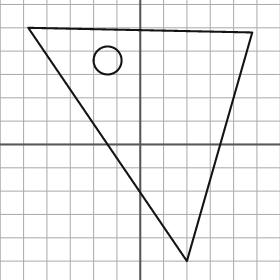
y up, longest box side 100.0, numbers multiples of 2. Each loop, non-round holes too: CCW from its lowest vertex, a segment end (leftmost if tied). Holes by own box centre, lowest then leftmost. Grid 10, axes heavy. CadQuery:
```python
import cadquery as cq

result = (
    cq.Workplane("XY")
    .moveTo(20.0, -50.0)
    .lineTo(48.0, 48.0)
    .lineTo(-48.0, 50.0)
    .close()
    .moveTo(-14.0, 36.0)
    .circle(6.0)
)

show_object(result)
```